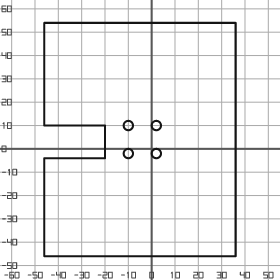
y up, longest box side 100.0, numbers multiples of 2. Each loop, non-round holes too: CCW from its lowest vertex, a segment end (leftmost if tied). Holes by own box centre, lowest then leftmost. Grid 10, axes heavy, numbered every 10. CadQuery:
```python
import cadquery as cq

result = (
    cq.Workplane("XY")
    .moveTo(-46.0, -46.0)
    .lineTo(36.0, -46.0)
    .lineTo(36.0, 54.0)
    .lineTo(-46.0, 54.0)
    .lineTo(-46.0, 10.0)
    .lineTo(-20.0, 10.0)
    .lineTo(-20.0, -4.0)
    .lineTo(-46.0, -4.0)
    .close()
    .moveTo(-10.0, -2.0)
    .circle(2.0)
    .moveTo(2.0, -2.0)
    .circle(2.0)
    .moveTo(-10.0, 10.0)
    .circle(2.0)
    .moveTo(2.0, 10.0)
    .circle(2.0)
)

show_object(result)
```